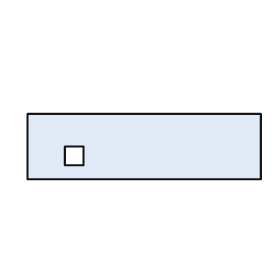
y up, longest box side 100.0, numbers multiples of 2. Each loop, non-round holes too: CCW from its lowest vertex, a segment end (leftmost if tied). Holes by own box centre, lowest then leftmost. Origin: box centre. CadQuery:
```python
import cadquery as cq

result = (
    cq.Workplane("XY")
    .moveTo(-50.0, -14.0)
    .lineTo(50.0, -14.0)
    .lineTo(50.0, 14.0)
    .lineTo(-50.0, 14.0)
    .close()
    .moveTo(-34.0, -8.0)
    .lineTo(-26.0, -8.0)
    .lineTo(-26.0, 0.0)
    .lineTo(-34.0, 0.0)
    .close()
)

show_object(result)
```